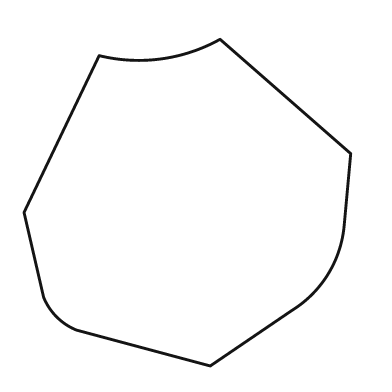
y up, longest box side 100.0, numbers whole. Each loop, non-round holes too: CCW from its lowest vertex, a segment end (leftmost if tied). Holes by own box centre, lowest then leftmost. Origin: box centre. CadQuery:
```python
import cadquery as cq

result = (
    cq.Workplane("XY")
    .moveTo(7.0, -50.0)
    .lineTo(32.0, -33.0)
    .threePointArc((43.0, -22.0), (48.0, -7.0))
    .lineTo(50.0, 15.0)
    .lineTo(10.0, 50.0)
    .threePointArc((-8.0, 44.0), (-27.0, 45.0))
    .lineTo(-50.0, -3.0)
    .lineTo(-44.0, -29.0)
    .threePointArc((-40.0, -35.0), (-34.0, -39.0))
    .close()
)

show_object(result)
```